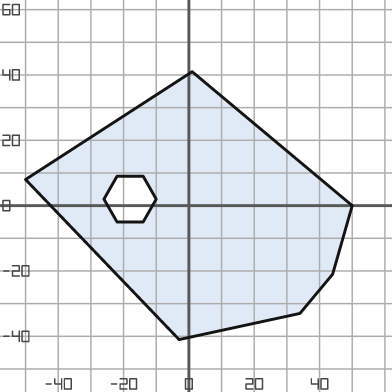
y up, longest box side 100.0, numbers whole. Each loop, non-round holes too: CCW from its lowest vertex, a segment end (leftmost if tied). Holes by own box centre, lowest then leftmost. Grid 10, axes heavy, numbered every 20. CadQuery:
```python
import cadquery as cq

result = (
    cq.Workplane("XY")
    .moveTo(-3.0, -41.0)
    .lineTo(34.0, -33.0)
    .lineTo(44.0, -21.0)
    .lineTo(50.0, 0.0)
    .lineTo(1.0, 41.0)
    .lineTo(-50.0, 8.0)
    .close()
    .moveTo(-22.0, -5.0)
    .lineTo(-14.0, -5.0)
    .lineTo(-10.0, 2.0)
    .lineTo(-14.0, 9.0)
    .lineTo(-22.0, 9.0)
    .lineTo(-26.0, 2.0)
    .close()
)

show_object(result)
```